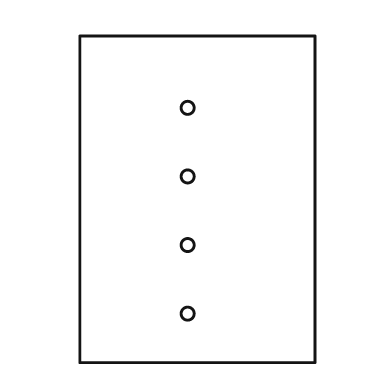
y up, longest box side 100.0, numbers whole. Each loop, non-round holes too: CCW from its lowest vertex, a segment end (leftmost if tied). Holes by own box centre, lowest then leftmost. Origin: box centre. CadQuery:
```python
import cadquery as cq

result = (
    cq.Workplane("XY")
    .moveTo(-36.0, -50.0)
    .lineTo(36.0, -50.0)
    .lineTo(36.0, 50.0)
    .lineTo(-36.0, 50.0)
    .close()
    .moveTo(-3.0, -35.0)
    .circle(2.0)
    .moveTo(-3.0, -14.0)
    .circle(2.0)
    .moveTo(-3.0, 7.0)
    .circle(2.0)
    .moveTo(-3.0, 28.0)
    .circle(2.0)
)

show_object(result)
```